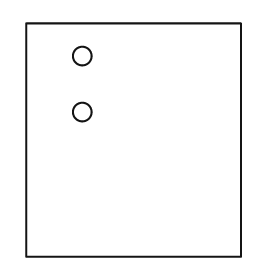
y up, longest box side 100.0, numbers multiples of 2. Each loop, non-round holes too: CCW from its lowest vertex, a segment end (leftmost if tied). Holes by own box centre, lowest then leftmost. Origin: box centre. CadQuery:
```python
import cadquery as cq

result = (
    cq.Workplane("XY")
    .moveTo(-46.0, -50.0)
    .lineTo(46.0, -50.0)
    .lineTo(46.0, 50.0)
    .lineTo(-46.0, 50.0)
    .close()
    .moveTo(-22.0, 12.0)
    .circle(4.0)
    .moveTo(-22.0, 36.0)
    .circle(4.0)
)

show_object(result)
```